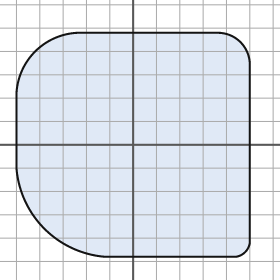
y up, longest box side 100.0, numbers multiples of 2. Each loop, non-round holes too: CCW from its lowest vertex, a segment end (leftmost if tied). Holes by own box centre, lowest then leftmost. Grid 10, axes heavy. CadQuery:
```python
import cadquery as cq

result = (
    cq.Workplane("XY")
    .moveTo(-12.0, -48.0)
    .lineTo(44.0, -48.0)
    .threePointArc((48.0, -46.0), (50.0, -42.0))
    .lineTo(50.0, 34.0)
    .threePointArc((46.0, 44.0), (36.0, 48.0))
    .lineTo(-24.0, 48.0)
    .threePointArc((-42.0, 40.0), (-50.0, 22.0))
    .lineTo(-50.0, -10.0)
    .threePointArc((-38.0, -36.0), (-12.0, -48.0))
    .close()
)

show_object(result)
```